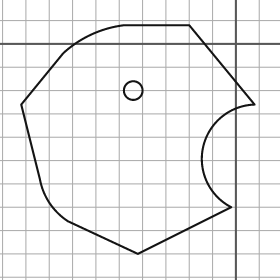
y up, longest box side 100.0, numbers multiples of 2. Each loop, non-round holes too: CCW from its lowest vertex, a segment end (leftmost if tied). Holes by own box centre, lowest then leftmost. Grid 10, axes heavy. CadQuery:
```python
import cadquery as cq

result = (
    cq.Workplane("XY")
    .moveTo(-42.0, -90.0)
    .lineTo(-2.0, -70.0)
    .threePointArc((-14.0, -44.0), (8.0, -26.0))
    .lineTo(-20.0, 8.0)
    .lineTo(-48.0, 8.0)
    .threePointArc((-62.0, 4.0), (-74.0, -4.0))
    .lineTo(-92.0, -26.0)
    .lineTo(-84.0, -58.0)
    .threePointArc((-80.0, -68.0), (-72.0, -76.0))
    .close()
    .moveTo(-44.0, -20.0)
    .circle(4.0)
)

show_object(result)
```